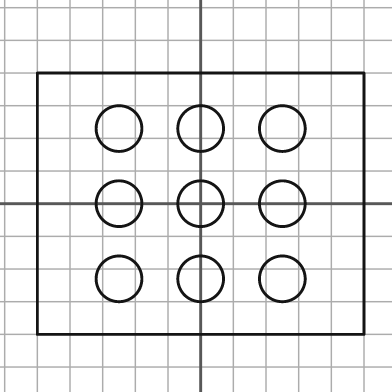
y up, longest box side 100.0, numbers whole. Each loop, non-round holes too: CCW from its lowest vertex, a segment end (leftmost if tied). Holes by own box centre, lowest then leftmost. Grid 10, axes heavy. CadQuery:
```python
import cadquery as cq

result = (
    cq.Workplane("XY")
    .moveTo(-50.0, -40.0)
    .lineTo(50.0, -40.0)
    .lineTo(50.0, 40.0)
    .lineTo(-50.0, 40.0)
    .close()
    .moveTo(-25.0, -23.0)
    .circle(7.0)
    .moveTo(0.0, -23.0)
    .circle(7.0)
    .moveTo(25.0, -23.0)
    .circle(7.0)
    .moveTo(-25.0, 0.0)
    .circle(7.0)
    .moveTo(0.0, 0.0)
    .circle(7.0)
    .moveTo(25.0, 0.0)
    .circle(7.0)
    .moveTo(-25.0, 23.0)
    .circle(7.0)
    .moveTo(0.0, 23.0)
    .circle(7.0)
    .moveTo(25.0, 23.0)
    .circle(7.0)
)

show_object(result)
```